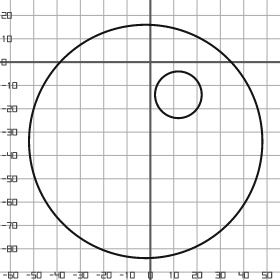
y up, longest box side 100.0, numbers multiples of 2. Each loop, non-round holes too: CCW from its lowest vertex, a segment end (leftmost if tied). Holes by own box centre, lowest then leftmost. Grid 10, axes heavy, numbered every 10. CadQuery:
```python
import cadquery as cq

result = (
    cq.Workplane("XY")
    .moveTo(-2.0, -34.0)
    .circle(50.0)
    .moveTo(12.0, -14.0)
    .circle(10.0)
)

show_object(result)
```